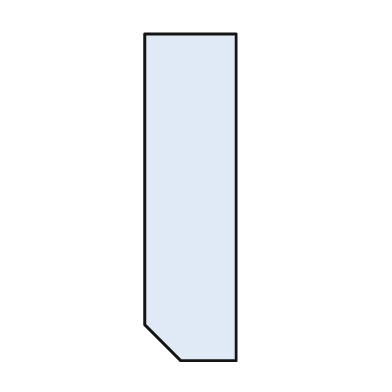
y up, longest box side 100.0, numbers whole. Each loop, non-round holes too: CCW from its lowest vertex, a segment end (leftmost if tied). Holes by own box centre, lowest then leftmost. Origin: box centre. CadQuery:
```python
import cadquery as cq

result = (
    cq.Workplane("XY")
    .moveTo(-3.0, -50.0)
    .lineTo(14.0, -50.0)
    .lineTo(14.0, 50.0)
    .lineTo(-14.0, 50.0)
    .lineTo(-14.0, -39.0)
    .close()
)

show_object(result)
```